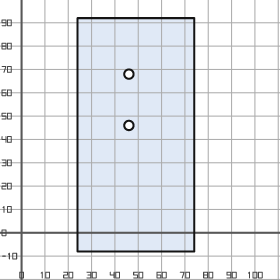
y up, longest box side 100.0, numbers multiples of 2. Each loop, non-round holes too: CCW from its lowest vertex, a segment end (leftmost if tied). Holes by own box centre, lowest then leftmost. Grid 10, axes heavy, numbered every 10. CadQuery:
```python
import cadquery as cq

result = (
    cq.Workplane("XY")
    .moveTo(24.0, -8.0)
    .lineTo(74.0, -8.0)
    .lineTo(74.0, 92.0)
    .lineTo(24.0, 92.0)
    .close()
    .moveTo(46.0, 46.0)
    .circle(2.0)
    .moveTo(46.0, 68.0)
    .circle(2.0)
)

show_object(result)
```